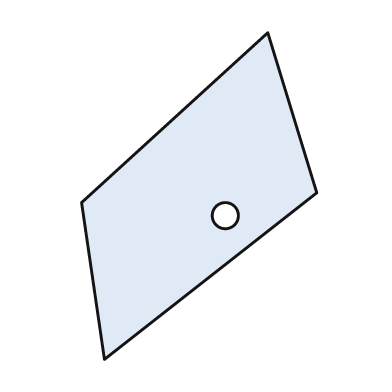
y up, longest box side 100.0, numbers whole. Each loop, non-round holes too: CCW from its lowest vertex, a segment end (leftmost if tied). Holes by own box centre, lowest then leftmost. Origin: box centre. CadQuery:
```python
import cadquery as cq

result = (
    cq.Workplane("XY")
    .moveTo(-29.0, -50.0)
    .lineTo(36.0, 1.0)
    .lineTo(21.0, 50.0)
    .lineTo(-36.0, -2.0)
    .close()
    .moveTo(8.0, -6.0)
    .circle(4.0)
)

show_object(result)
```